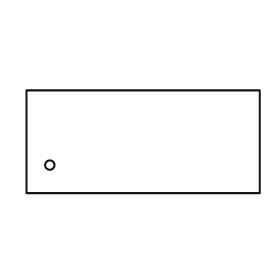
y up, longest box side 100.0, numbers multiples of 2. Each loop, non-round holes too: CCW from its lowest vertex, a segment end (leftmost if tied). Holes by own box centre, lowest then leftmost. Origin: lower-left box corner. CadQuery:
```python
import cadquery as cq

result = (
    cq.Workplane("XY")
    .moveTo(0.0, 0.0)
    .lineTo(100.0, 0.0)
    .lineTo(100.0, 44.0)
    .lineTo(0.0, 44.0)
    .close()
    .moveTo(10.0, 12.0)
    .circle(2.0)
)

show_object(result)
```